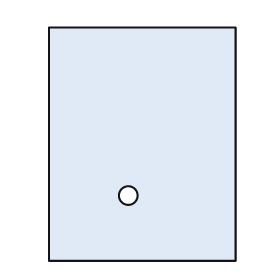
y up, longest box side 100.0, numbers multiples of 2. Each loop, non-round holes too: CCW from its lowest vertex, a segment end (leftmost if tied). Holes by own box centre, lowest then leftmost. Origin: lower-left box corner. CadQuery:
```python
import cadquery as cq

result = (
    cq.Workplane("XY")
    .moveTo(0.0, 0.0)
    .lineTo(80.0, 0.0)
    .lineTo(80.0, 100.0)
    .lineTo(0.0, 100.0)
    .close()
    .moveTo(34.0, 28.0)
    .circle(4.0)
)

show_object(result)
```